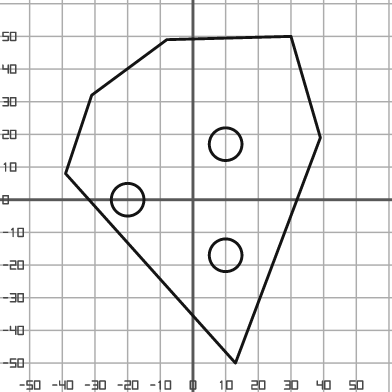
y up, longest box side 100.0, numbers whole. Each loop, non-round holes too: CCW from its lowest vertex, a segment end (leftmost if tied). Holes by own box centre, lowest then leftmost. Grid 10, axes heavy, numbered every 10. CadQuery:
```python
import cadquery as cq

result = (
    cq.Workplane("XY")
    .moveTo(13.0, -50.0)
    .lineTo(39.0, 19.0)
    .lineTo(30.0, 50.0)
    .lineTo(-8.0, 49.0)
    .lineTo(-31.0, 32.0)
    .lineTo(-39.0, 8.0)
    .close()
    .moveTo(10.0, -17.0)
    .circle(5.0)
    .moveTo(-20.0, 0.0)
    .circle(5.0)
    .moveTo(10.0, 17.0)
    .circle(5.0)
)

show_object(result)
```